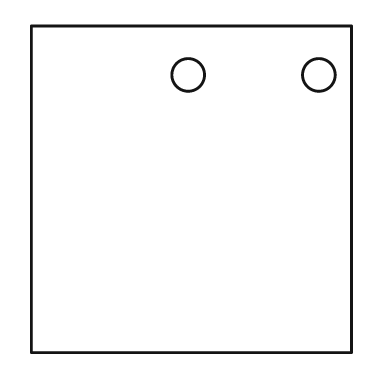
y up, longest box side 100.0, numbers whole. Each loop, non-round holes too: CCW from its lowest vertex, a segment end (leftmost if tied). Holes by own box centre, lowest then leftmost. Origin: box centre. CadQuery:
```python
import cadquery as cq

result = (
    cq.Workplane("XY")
    .moveTo(-49.0, -50.0)
    .lineTo(49.0, -50.0)
    .lineTo(49.0, 50.0)
    .lineTo(-49.0, 50.0)
    .close()
    .moveTo(-1.0, 35.0)
    .circle(5.0)
    .moveTo(39.0, 35.0)
    .circle(5.0)
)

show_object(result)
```